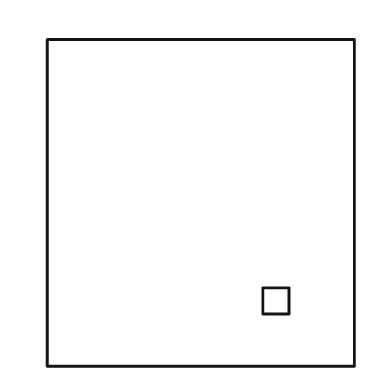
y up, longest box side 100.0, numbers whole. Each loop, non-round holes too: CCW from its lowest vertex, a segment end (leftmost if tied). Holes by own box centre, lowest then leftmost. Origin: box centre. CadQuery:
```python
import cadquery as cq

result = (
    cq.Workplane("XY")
    .moveTo(-47.0, -50.0)
    .lineTo(47.0, -50.0)
    .lineTo(47.0, 50.0)
    .lineTo(-47.0, 50.0)
    .close()
    .moveTo(19.0, -34.0)
    .lineTo(27.0, -34.0)
    .lineTo(27.0, -26.0)
    .lineTo(19.0, -26.0)
    .close()
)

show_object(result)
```